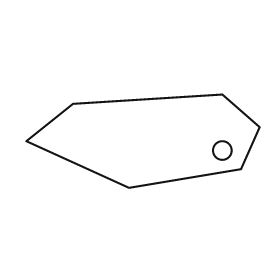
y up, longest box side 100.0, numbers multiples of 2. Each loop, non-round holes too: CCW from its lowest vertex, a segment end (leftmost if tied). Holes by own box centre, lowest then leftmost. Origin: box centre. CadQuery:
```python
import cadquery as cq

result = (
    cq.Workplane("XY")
    .moveTo(-6.0, -20.0)
    .lineTo(42.0, -12.0)
    .lineTo(50.0, 6.0)
    .lineTo(34.0, 20.0)
    .lineTo(-30.0, 16.0)
    .lineTo(-50.0, 0.0)
    .close()
    .moveTo(34.0, -4.0)
    .circle(4.0)
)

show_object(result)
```